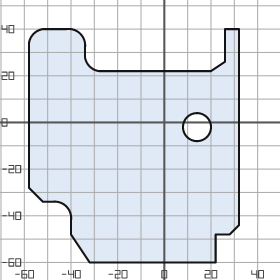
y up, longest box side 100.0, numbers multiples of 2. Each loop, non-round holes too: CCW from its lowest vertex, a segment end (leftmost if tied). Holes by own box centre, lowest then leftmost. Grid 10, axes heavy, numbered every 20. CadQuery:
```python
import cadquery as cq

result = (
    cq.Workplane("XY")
    .moveTo(-32.0, -60.0)
    .lineTo(22.0, -60.0)
    .lineTo(22.0, -48.0)
    .lineTo(28.0, -48.0)
    .lineTo(32.0, -44.0)
    .lineTo(32.0, 40.0)
    .lineTo(26.0, 40.0)
    .lineTo(26.0, 26.0)
    .lineTo(20.0, 22.0)
    .lineTo(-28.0, 22.0)
    .threePointArc((-32.0, 24.0), (-34.0, 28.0))
    .lineTo(-34.0, 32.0)
    .threePointArc((-36.0, 38.0), (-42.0, 40.0))
    .lineTo(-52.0, 40.0)
    .threePointArc((-56.0, 38.0), (-58.0, 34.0))
    .lineTo(-58.0, -28.0)
    .lineTo(-52.0, -34.0)
    .lineTo(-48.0, -34.0)
    .threePointArc((-42.0, -36.0), (-40.0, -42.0))
    .lineTo(-40.0, -48.0)
    .close()
    .moveTo(14.0, -2.0)
    .circle(6.0)
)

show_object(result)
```